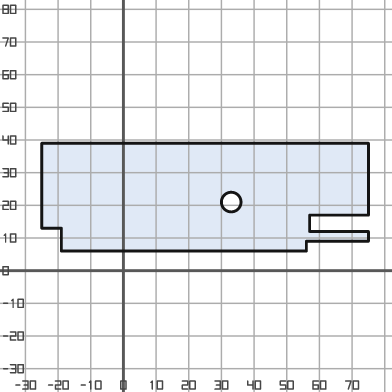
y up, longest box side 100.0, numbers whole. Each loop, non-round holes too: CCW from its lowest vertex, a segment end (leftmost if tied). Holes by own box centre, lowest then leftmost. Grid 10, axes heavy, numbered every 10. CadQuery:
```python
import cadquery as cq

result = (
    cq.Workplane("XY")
    .moveTo(-19.0, 6.0)
    .lineTo(56.0, 6.0)
    .lineTo(56.0, 9.0)
    .lineTo(75.0, 9.0)
    .lineTo(75.0, 12.0)
    .lineTo(57.0, 12.0)
    .lineTo(57.0, 17.0)
    .lineTo(75.0, 17.0)
    .lineTo(75.0, 39.0)
    .lineTo(-25.0, 39.0)
    .lineTo(-25.0, 13.0)
    .lineTo(-19.0, 13.0)
    .close()
    .moveTo(33.0, 21.0)
    .circle(3.0)
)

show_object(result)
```